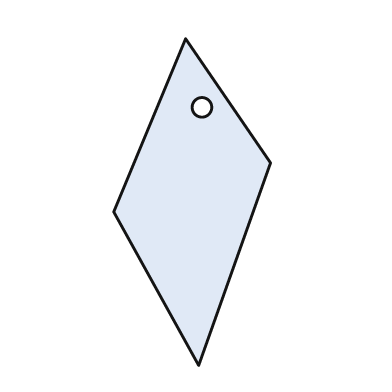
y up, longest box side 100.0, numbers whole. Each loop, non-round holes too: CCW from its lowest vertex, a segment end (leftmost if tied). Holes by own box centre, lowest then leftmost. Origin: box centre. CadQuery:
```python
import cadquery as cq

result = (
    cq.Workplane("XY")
    .moveTo(2.0, -50.0)
    .lineTo(24.0, 12.0)
    .lineTo(-2.0, 50.0)
    .lineTo(-24.0, -3.0)
    .close()
    .moveTo(3.0, 29.0)
    .circle(3.0)
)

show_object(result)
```